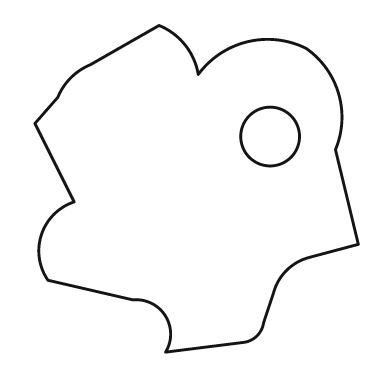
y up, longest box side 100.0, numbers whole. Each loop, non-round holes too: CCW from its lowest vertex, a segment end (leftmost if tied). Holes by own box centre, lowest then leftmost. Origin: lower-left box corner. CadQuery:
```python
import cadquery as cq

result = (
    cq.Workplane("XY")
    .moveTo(40.0, 0.0)
    .lineTo(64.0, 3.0)
    .threePointArc((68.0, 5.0), (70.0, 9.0))
    .lineTo(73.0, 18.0)
    .threePointArc((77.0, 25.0), (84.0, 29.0))
    .lineTo(99.0, 33.0)
    .lineTo(92.0, 62.0)
    .threePointArc((93.0, 79.0), (83.0, 93.0))
    .threePointArc((65.0, 95.0), (50.0, 85.0))
    .threePointArc((46.0, 94.0), (38.0, 100.0))
    .lineTo(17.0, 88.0)
    .threePointArc((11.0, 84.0), (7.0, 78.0))
    .lineTo(0.0, 70.0)
    .lineTo(12.0, 46.0)
    .threePointArc((2.0, 36.0), (4.0, 22.0))
    .lineTo(30.0, 16.0)
    .threePointArc((40.0, 11.0), (40.0, 0.0))
    .close()
    .moveTo(72.0, 66.0)
    .circle(9.0)
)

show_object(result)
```